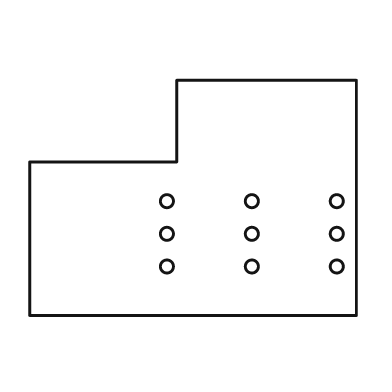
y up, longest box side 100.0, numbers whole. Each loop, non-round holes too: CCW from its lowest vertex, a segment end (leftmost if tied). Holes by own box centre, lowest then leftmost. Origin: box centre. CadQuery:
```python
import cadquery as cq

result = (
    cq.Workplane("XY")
    .moveTo(-50.0, -36.0)
    .lineTo(50.0, -36.0)
    .lineTo(50.0, 36.0)
    .lineTo(-5.0, 36.0)
    .lineTo(-5.0, 11.0)
    .lineTo(-50.0, 11.0)
    .close()
    .moveTo(-8.0, -21.0)
    .circle(2.0)
    .moveTo(18.0, -21.0)
    .circle(2.0)
    .moveTo(44.0, -21.0)
    .circle(2.0)
    .moveTo(-8.0, -11.0)
    .circle(2.0)
    .moveTo(18.0, -11.0)
    .circle(2.0)
    .moveTo(44.0, -11.0)
    .circle(2.0)
    .moveTo(-8.0, -1.0)
    .circle(2.0)
    .moveTo(18.0, -1.0)
    .circle(2.0)
    .moveTo(44.0, -1.0)
    .circle(2.0)
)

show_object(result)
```